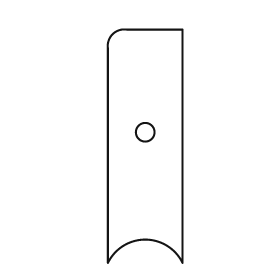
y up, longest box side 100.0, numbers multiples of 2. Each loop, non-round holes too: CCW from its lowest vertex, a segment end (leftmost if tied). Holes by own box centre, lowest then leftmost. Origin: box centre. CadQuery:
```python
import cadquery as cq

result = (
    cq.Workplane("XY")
    .moveTo(-16.0, -50.0)
    .threePointArc((0.0, -40.0), (16.0, -50.0))
    .lineTo(16.0, 50.0)
    .lineTo(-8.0, 50.0)
    .threePointArc((-14.0, 48.0), (-16.0, 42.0))
    .close()
    .moveTo(0.0, 6.0)
    .circle(4.0)
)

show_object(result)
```